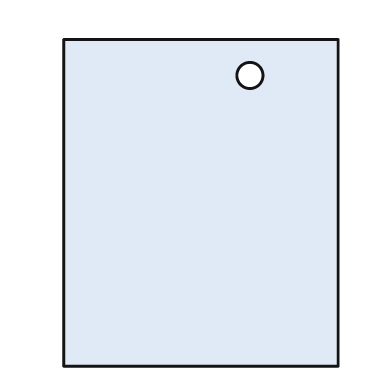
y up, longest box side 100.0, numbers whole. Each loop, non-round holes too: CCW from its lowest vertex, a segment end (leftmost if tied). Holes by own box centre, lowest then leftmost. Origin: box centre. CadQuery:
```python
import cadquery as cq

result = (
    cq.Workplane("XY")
    .moveTo(-42.0, -50.0)
    .lineTo(42.0, -50.0)
    .lineTo(42.0, 50.0)
    .lineTo(-42.0, 50.0)
    .close()
    .moveTo(15.0, 39.0)
    .circle(4.0)
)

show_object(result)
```